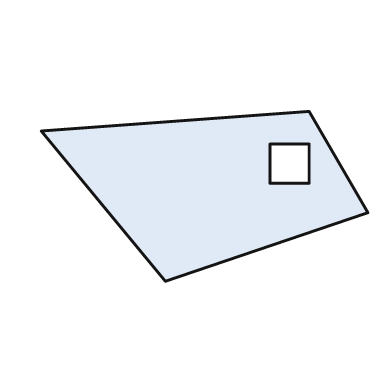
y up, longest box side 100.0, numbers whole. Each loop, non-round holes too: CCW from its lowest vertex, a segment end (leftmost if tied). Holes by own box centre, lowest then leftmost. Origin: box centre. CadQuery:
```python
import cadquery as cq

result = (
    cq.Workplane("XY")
    .moveTo(-12.0, -26.0)
    .lineTo(50.0, -5.0)
    .lineTo(32.0, 26.0)
    .lineTo(-50.0, 20.0)
    .close()
    .moveTo(20.0, 4.0)
    .lineTo(32.0, 4.0)
    .lineTo(32.0, 16.0)
    .lineTo(20.0, 16.0)
    .close()
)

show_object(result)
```